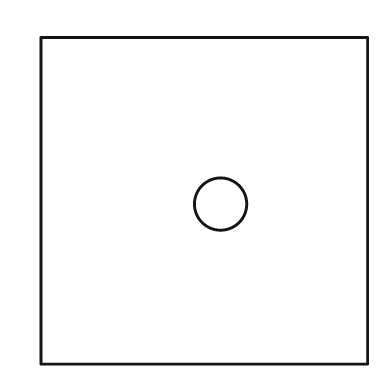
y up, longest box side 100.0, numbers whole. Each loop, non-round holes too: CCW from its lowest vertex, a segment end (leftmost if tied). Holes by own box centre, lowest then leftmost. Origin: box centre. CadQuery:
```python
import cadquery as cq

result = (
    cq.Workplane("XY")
    .moveTo(-50.0, -50.0)
    .lineTo(50.0, -50.0)
    .lineTo(50.0, 50.0)
    .lineTo(-50.0, 50.0)
    .close()
    .moveTo(5.0, -1.0)
    .circle(8.0)
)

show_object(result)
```